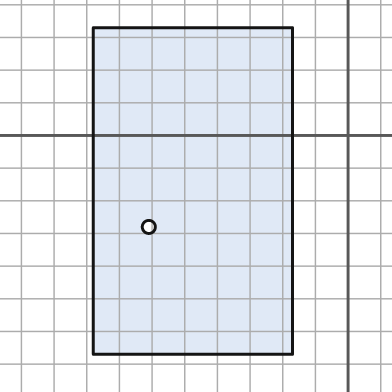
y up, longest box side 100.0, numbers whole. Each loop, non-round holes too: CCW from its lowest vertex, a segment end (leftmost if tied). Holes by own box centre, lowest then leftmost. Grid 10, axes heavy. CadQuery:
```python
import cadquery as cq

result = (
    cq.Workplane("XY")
    .moveTo(-78.0, -67.0)
    .lineTo(-17.0, -67.0)
    .lineTo(-17.0, 33.0)
    .lineTo(-78.0, 33.0)
    .close()
    .moveTo(-61.0, -28.0)
    .circle(2.0)
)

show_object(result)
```